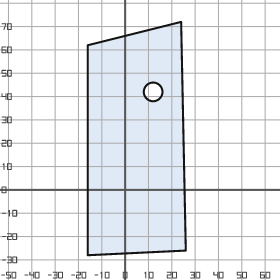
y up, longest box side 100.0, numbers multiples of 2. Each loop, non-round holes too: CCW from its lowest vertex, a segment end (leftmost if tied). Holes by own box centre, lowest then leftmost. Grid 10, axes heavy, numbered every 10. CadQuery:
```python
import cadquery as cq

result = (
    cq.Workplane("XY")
    .moveTo(-16.0, -28.0)
    .lineTo(26.0, -26.0)
    .lineTo(24.0, 72.0)
    .lineTo(-16.0, 62.0)
    .close()
    .moveTo(12.0, 42.0)
    .circle(4.0)
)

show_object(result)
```